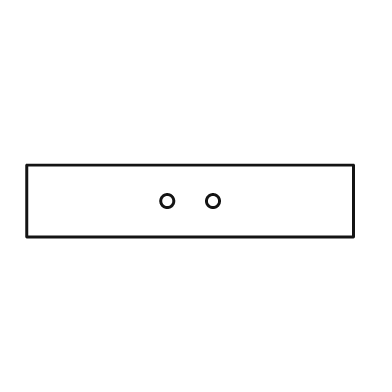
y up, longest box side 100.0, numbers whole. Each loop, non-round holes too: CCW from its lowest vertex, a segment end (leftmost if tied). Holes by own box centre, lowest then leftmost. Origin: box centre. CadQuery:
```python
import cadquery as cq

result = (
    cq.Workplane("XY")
    .moveTo(-50.0, -11.0)
    .lineTo(50.0, -11.0)
    .lineTo(50.0, 11.0)
    .lineTo(-50.0, 11.0)
    .close()
    .moveTo(-7.0, 0.0)
    .circle(2.0)
    .moveTo(7.0, 0.0)
    .circle(2.0)
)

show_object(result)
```